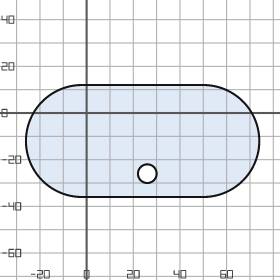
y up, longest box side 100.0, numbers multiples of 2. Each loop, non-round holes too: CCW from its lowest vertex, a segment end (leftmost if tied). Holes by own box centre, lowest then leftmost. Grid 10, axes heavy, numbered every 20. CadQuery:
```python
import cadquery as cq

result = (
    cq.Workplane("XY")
    .moveTo(-2.0, -36.0)
    .lineTo(50.0, -36.0)
    .threePointArc((74.0, -12.0), (50.0, 12.0))
    .lineTo(-2.0, 12.0)
    .threePointArc((-26.0, -12.0), (-2.0, -36.0))
    .close()
    .moveTo(26.0, -26.0)
    .circle(4.0)
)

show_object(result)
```